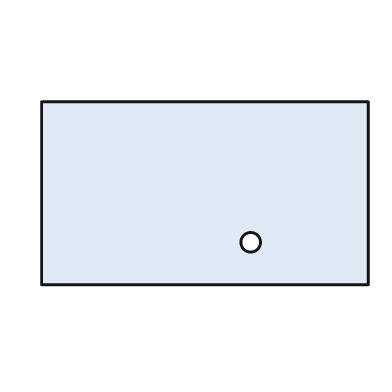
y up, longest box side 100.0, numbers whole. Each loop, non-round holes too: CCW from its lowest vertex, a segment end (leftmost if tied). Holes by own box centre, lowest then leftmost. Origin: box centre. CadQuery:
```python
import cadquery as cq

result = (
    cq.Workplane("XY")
    .moveTo(-50.0, -28.0)
    .lineTo(50.0, -28.0)
    .lineTo(50.0, 28.0)
    .lineTo(-50.0, 28.0)
    .close()
    .moveTo(14.0, -15.0)
    .circle(3.0)
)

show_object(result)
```